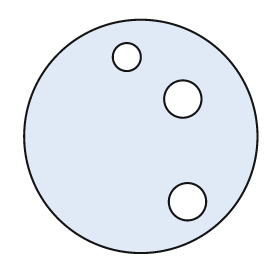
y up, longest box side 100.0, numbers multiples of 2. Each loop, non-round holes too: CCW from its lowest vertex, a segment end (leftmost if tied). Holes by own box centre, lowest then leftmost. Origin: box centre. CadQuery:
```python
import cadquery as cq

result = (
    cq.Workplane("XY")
    .moveTo(0.0, 0.0)
    .circle(50.0)
    .moveTo(20.0, -28.0)
    .circle(8.0)
    .moveTo(18.0, 16.0)
    .circle(8.0)
    .moveTo(-6.0, 34.0)
    .circle(6.0)
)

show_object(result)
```